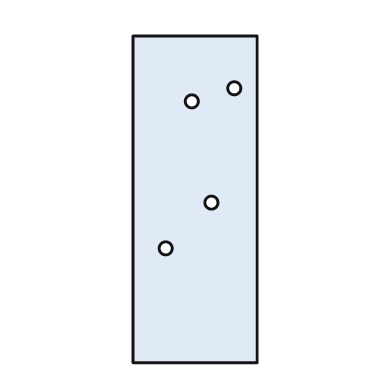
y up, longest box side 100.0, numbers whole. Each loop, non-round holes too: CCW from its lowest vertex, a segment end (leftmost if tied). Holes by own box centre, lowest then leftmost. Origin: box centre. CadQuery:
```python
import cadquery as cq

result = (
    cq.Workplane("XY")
    .moveTo(-19.0, -50.0)
    .lineTo(19.0, -50.0)
    .lineTo(19.0, 50.0)
    .lineTo(-19.0, 50.0)
    .close()
    .moveTo(-9.0, -15.0)
    .circle(2.0)
    .moveTo(5.0, -1.0)
    .circle(2.0)
    .moveTo(-1.0, 30.0)
    .circle(2.0)
    .moveTo(12.0, 34.0)
    .circle(2.0)
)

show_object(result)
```